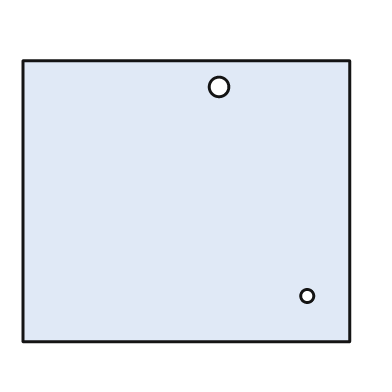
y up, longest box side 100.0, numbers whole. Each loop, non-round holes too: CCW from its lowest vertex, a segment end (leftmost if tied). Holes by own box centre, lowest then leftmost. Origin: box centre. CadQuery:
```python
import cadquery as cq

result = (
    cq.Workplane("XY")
    .moveTo(-50.0, -43.0)
    .lineTo(50.0, -43.0)
    .lineTo(50.0, 43.0)
    .lineTo(-50.0, 43.0)
    .close()
    .moveTo(37.0, -29.0)
    .circle(2.0)
    .moveTo(10.0, 35.0)
    .circle(3.0)
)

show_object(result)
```